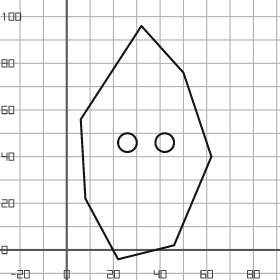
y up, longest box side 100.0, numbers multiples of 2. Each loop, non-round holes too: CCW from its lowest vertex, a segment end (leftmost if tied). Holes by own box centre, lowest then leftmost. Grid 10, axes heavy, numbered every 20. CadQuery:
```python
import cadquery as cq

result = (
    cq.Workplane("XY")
    .moveTo(22.0, -4.0)
    .lineTo(46.0, 2.0)
    .lineTo(62.0, 40.0)
    .lineTo(50.0, 76.0)
    .lineTo(32.0, 96.0)
    .lineTo(6.0, 56.0)
    .lineTo(8.0, 22.0)
    .close()
    .moveTo(26.0, 46.0)
    .circle(4.0)
    .moveTo(42.0, 46.0)
    .circle(4.0)
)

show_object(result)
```